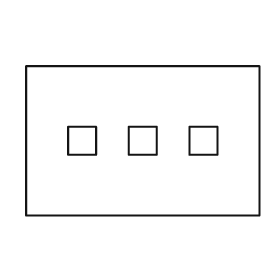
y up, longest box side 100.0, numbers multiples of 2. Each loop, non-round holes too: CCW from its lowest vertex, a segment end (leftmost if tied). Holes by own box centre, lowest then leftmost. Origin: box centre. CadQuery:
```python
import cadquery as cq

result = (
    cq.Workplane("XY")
    .moveTo(-50.0, -32.0)
    .lineTo(50.0, -32.0)
    .lineTo(50.0, 32.0)
    .lineTo(-50.0, 32.0)
    .close()
    .moveTo(-32.0, -6.0)
    .lineTo(-20.0, -6.0)
    .lineTo(-20.0, 6.0)
    .lineTo(-32.0, 6.0)
    .close()
    .moveTo(-6.0, -6.0)
    .lineTo(6.0, -6.0)
    .lineTo(6.0, 6.0)
    .lineTo(-6.0, 6.0)
    .close()
    .moveTo(20.0, -6.0)
    .lineTo(32.0, -6.0)
    .lineTo(32.0, 6.0)
    .lineTo(20.0, 6.0)
    .close()
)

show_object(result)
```